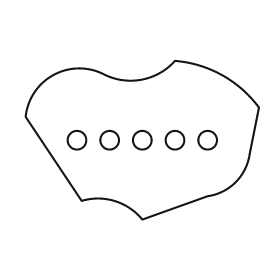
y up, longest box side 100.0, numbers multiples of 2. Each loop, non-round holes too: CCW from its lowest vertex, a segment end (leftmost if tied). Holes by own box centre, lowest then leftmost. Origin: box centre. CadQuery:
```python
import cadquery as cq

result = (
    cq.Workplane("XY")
    .moveTo(0.0, -34.0)
    .lineTo(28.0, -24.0)
    .threePointArc((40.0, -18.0), (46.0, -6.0))
    .lineTo(50.0, 14.0)
    .threePointArc((34.0, 28.0), (14.0, 34.0))
    .threePointArc((0.0, 26.0), (-16.0, 28.0))
    .threePointArc((-38.0, 28.0), (-50.0, 10.0))
    .lineTo(-26.0, -26.0)
    .threePointArc((-12.0, -26.0), (0.0, -34.0))
    .close()
    .moveTo(-28.0, 0.0)
    .circle(4.0)
    .moveTo(-14.0, 0.0)
    .circle(4.0)
    .moveTo(0.0, 0.0)
    .circle(4.0)
    .moveTo(14.0, 0.0)
    .circle(4.0)
    .moveTo(28.0, 0.0)
    .circle(4.0)
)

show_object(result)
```